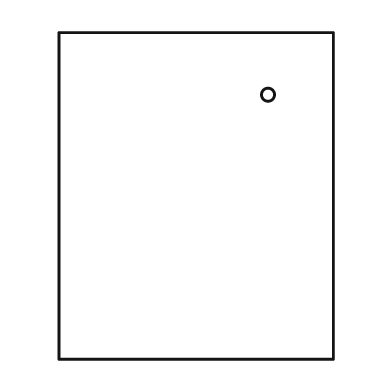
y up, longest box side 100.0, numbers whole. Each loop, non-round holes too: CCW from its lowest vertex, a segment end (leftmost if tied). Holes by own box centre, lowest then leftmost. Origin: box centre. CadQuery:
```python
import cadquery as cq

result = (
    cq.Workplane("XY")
    .moveTo(-42.0, -50.0)
    .lineTo(42.0, -50.0)
    .lineTo(42.0, 50.0)
    .lineTo(-42.0, 50.0)
    .close()
    .moveTo(22.0, 31.0)
    .circle(2.0)
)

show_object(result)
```